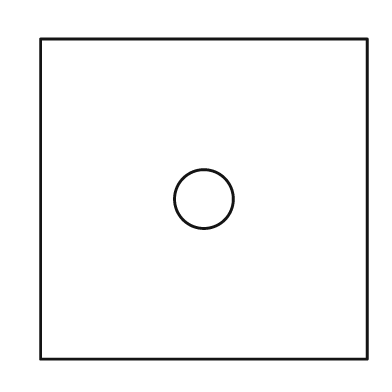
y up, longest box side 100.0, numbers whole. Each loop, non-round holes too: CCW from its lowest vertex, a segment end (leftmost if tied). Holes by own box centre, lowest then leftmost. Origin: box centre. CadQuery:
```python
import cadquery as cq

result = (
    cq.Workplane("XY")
    .moveTo(-50.0, -49.0)
    .lineTo(50.0, -49.0)
    .lineTo(50.0, 49.0)
    .lineTo(-50.0, 49.0)
    .close()
    .moveTo(0.0, 0.0)
    .circle(9.0)
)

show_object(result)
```